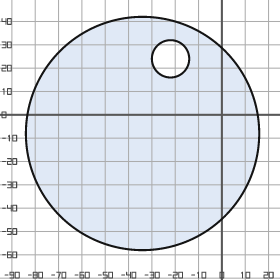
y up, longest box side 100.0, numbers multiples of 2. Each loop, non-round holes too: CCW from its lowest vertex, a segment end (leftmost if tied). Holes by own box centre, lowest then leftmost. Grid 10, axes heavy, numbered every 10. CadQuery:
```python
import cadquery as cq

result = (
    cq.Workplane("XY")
    .moveTo(-34.0, -8.0)
    .circle(50.0)
    .moveTo(-22.0, 24.0)
    .circle(8.0)
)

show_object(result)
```